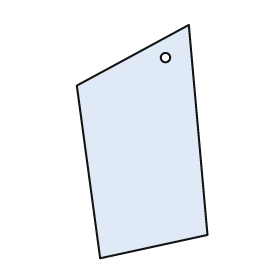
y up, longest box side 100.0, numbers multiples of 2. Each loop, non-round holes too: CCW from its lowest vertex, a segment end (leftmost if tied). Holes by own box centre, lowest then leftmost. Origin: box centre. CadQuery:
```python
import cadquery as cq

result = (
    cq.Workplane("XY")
    .moveTo(-18.0, -50.0)
    .lineTo(28.0, -40.0)
    .lineTo(20.0, 50.0)
    .lineTo(-28.0, 24.0)
    .close()
    .moveTo(10.0, 36.0)
    .circle(2.0)
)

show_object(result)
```